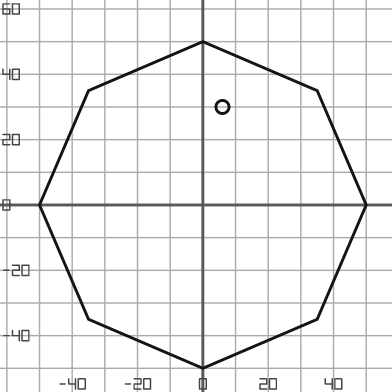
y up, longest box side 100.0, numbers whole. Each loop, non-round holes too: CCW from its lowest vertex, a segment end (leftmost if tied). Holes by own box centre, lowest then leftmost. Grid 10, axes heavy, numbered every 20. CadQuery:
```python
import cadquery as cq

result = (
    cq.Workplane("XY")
    .moveTo(0.0, -50.0)
    .lineTo(35.0, -35.0)
    .lineTo(50.0, 0.0)
    .lineTo(35.0, 35.0)
    .lineTo(0.0, 50.0)
    .lineTo(-35.0, 35.0)
    .lineTo(-50.0, 0.0)
    .lineTo(-35.0, -35.0)
    .close()
    .moveTo(6.0, 30.0)
    .circle(2.0)
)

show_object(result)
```